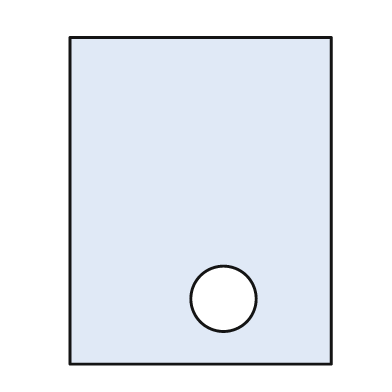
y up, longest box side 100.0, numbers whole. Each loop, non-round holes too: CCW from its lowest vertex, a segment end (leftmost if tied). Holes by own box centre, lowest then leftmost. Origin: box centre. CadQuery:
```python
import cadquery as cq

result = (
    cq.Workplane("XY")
    .moveTo(-40.0, -50.0)
    .lineTo(40.0, -50.0)
    .lineTo(40.0, 50.0)
    .lineTo(-40.0, 50.0)
    .close()
    .moveTo(7.0, -30.0)
    .circle(10.0)
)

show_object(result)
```